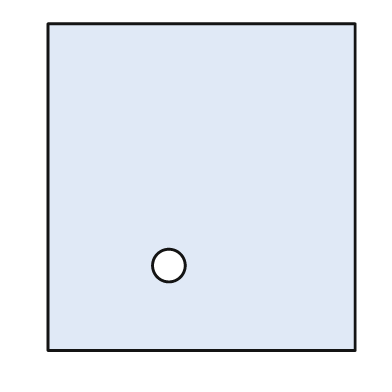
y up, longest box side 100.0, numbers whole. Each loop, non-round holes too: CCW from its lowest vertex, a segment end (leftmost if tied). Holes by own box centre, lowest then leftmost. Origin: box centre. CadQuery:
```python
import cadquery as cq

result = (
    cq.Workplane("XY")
    .moveTo(-47.0, -50.0)
    .lineTo(47.0, -50.0)
    .lineTo(47.0, 50.0)
    .lineTo(-47.0, 50.0)
    .close()
    .moveTo(-10.0, -24.0)
    .circle(5.0)
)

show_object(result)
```